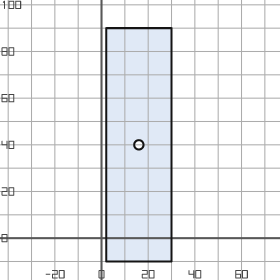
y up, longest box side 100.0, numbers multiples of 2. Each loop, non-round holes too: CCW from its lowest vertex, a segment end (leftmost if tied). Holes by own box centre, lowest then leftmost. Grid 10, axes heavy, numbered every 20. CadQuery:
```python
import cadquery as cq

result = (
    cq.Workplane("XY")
    .moveTo(2.0, -10.0)
    .lineTo(30.0, -10.0)
    .lineTo(30.0, 90.0)
    .lineTo(2.0, 90.0)
    .close()
    .moveTo(16.0, 40.0)
    .circle(2.0)
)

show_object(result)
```